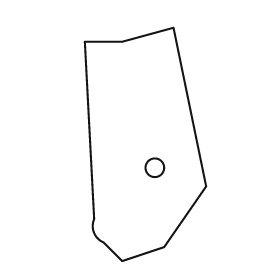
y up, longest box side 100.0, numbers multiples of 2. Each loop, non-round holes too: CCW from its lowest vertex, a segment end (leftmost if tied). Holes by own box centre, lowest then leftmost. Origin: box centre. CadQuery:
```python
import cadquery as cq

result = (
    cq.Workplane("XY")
    .moveTo(-10.0, -50.0)
    .lineTo(8.0, -44.0)
    .lineTo(26.0, -18.0)
    .lineTo(12.0, 50.0)
    .lineTo(-10.0, 44.0)
    .lineTo(-26.0, 44.0)
    .lineTo(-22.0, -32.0)
    .threePointArc((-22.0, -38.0), (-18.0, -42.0))
    .close()
    .moveTo(4.0, -10.0)
    .circle(4.0)
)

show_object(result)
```